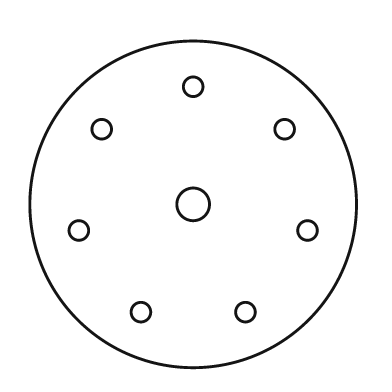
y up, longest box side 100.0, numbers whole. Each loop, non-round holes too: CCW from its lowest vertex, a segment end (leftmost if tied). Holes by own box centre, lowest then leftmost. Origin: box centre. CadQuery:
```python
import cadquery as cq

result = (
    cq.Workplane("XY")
    .moveTo(0.0, 0.0)
    .circle(50.0)
    .moveTo(-16.0, -33.0)
    .circle(3.0)
    .moveTo(16.0, -33.0)
    .circle(3.0)
    .moveTo(-35.0, -8.0)
    .circle(3.0)
    .moveTo(35.0, -8.0)
    .circle(3.0)
    .moveTo(0.0, 0.0)
    .circle(5.0)
    .moveTo(-28.0, 23.0)
    .circle(3.0)
    .moveTo(28.0, 23.0)
    .circle(3.0)
    .moveTo(0.0, 36.0)
    .circle(3.0)
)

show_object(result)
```